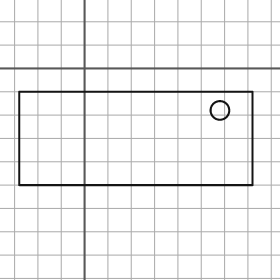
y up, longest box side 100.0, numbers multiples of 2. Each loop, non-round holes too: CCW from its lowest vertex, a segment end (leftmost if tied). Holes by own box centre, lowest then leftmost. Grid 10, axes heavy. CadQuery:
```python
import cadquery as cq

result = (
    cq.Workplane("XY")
    .moveTo(-28.0, -50.0)
    .lineTo(72.0, -50.0)
    .lineTo(72.0, -10.0)
    .lineTo(-28.0, -10.0)
    .close()
    .moveTo(58.0, -18.0)
    .circle(4.0)
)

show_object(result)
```